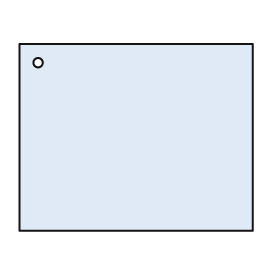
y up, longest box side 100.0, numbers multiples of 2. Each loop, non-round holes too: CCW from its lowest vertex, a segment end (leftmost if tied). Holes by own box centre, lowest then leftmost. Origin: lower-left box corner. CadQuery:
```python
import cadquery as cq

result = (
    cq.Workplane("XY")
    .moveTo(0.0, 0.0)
    .lineTo(100.0, 0.0)
    .lineTo(100.0, 80.0)
    .lineTo(0.0, 80.0)
    .close()
    .moveTo(8.0, 72.0)
    .circle(2.0)
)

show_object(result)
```